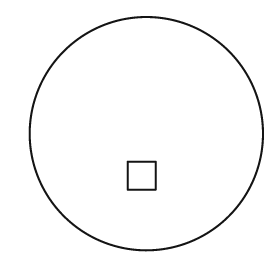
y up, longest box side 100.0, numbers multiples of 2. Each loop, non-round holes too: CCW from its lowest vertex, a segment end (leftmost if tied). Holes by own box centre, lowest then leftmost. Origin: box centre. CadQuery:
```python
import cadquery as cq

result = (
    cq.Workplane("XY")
    .moveTo(0.0, 0.0)
    .circle(50.0)
    .moveTo(-8.0, -24.0)
    .lineTo(4.0, -24.0)
    .lineTo(4.0, -12.0)
    .lineTo(-8.0, -12.0)
    .close()
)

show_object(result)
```